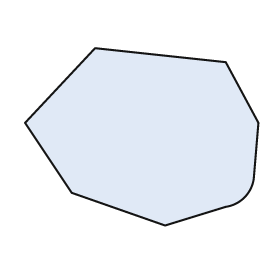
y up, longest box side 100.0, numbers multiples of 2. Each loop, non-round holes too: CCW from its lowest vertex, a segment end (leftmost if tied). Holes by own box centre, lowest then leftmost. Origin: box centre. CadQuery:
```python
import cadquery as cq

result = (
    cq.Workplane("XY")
    .moveTo(10.0, -38.0)
    .lineTo(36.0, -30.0)
    .threePointArc((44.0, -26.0), (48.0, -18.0))
    .lineTo(50.0, 6.0)
    .lineTo(36.0, 32.0)
    .lineTo(-20.0, 38.0)
    .lineTo(-50.0, 6.0)
    .lineTo(-30.0, -24.0)
    .close()
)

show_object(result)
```